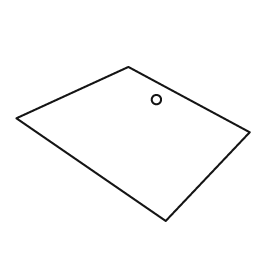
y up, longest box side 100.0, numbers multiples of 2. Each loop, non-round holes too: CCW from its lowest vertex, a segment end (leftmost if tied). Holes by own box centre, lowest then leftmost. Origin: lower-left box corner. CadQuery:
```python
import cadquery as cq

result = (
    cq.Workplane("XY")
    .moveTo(64.0, 0.0)
    .lineTo(100.0, 38.0)
    .lineTo(48.0, 66.0)
    .lineTo(0.0, 44.0)
    .close()
    .moveTo(60.0, 52.0)
    .circle(2.0)
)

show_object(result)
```